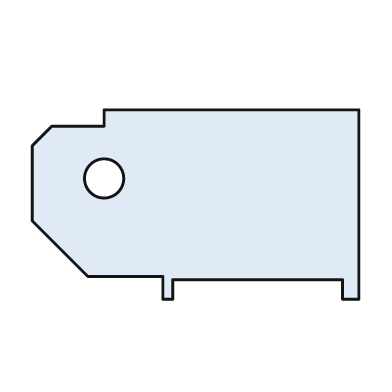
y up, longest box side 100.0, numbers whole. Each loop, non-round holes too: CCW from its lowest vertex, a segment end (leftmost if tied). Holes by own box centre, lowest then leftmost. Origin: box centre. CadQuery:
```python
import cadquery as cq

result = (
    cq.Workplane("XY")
    .moveTo(-10.0, -29.0)
    .lineTo(-7.0, -29.0)
    .lineTo(-7.0, -23.0)
    .lineTo(45.0, -23.0)
    .lineTo(45.0, -29.0)
    .lineTo(50.0, -29.0)
    .lineTo(50.0, 29.0)
    .lineTo(-28.0, 29.0)
    .lineTo(-28.0, 24.0)
    .lineTo(-44.0, 24.0)
    .lineTo(-50.0, 18.0)
    .lineTo(-50.0, -5.0)
    .lineTo(-33.0, -22.0)
    .lineTo(-10.0, -22.0)
    .close()
    .moveTo(-28.0, 8.0)
    .circle(6.0)
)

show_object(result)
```